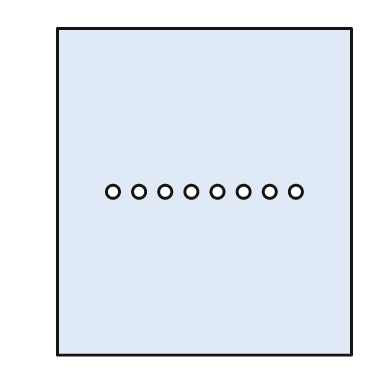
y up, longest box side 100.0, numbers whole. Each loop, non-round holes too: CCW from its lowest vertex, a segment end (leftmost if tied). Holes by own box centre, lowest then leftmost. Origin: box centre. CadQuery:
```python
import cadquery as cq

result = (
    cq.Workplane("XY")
    .moveTo(-45.0, -50.0)
    .lineTo(45.0, -50.0)
    .lineTo(45.0, 50.0)
    .lineTo(-45.0, 50.0)
    .close()
    .moveTo(-28.0, 0.0)
    .circle(2.0)
    .moveTo(-20.0, 0.0)
    .circle(2.0)
    .moveTo(-12.0, 0.0)
    .circle(2.0)
    .moveTo(-4.0, 0.0)
    .circle(2.0)
    .moveTo(4.0, 0.0)
    .circle(2.0)
    .moveTo(12.0, 0.0)
    .circle(2.0)
    .moveTo(20.0, 0.0)
    .circle(2.0)
    .moveTo(28.0, 0.0)
    .circle(2.0)
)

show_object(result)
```